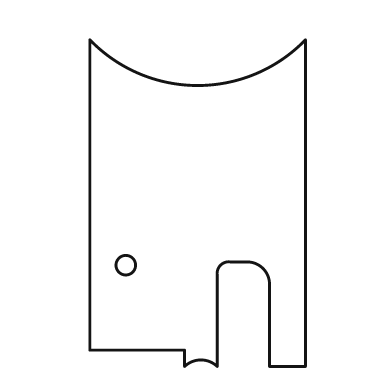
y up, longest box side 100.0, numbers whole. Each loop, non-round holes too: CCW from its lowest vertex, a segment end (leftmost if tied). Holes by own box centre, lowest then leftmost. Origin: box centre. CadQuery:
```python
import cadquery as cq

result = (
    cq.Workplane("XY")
    .moveTo(-4.0, -50.0)
    .threePointArc((1.0, -48.0), (6.0, -50.0))
    .lineTo(6.0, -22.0)
    .threePointArc((7.0, -19.0), (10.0, -18.0))
    .lineTo(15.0, -18.0)
    .threePointArc((20.0, -20.0), (22.0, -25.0))
    .lineTo(22.0, -50.0)
    .lineTo(33.0, -50.0)
    .lineTo(33.0, 50.0)
    .threePointArc((0.0, 36.0), (-33.0, 50.0))
    .lineTo(-33.0, -45.0)
    .lineTo(-4.0, -45.0)
    .close()
    .moveTo(-22.0, -19.0)
    .circle(3.0)
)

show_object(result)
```